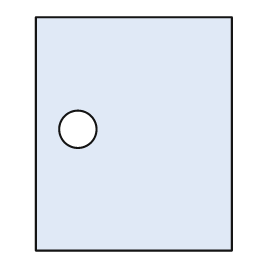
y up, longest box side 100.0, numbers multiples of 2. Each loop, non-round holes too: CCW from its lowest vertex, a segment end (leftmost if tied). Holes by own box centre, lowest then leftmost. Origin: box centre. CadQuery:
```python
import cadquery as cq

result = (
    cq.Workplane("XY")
    .moveTo(-42.0, -50.0)
    .lineTo(42.0, -50.0)
    .lineTo(42.0, 50.0)
    .lineTo(-42.0, 50.0)
    .close()
    .moveTo(-24.0, 2.0)
    .circle(8.0)
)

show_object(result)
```